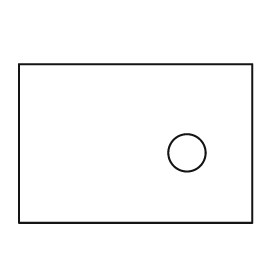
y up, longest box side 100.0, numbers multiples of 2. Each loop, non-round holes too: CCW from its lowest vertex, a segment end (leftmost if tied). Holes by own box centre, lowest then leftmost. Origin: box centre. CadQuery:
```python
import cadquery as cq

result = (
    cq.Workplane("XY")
    .moveTo(-50.0, -34.0)
    .lineTo(50.0, -34.0)
    .lineTo(50.0, 34.0)
    .lineTo(-50.0, 34.0)
    .close()
    .moveTo(22.0, -4.0)
    .circle(8.0)
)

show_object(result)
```